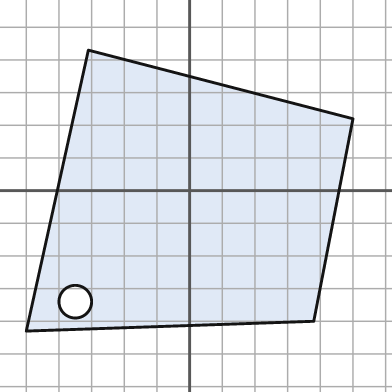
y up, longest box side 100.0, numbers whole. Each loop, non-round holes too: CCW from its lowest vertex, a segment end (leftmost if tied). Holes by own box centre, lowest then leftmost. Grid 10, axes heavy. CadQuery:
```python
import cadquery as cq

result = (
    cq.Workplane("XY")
    .moveTo(-50.0, -43.0)
    .lineTo(38.0, -40.0)
    .lineTo(50.0, 22.0)
    .lineTo(-31.0, 43.0)
    .close()
    .moveTo(-35.0, -34.0)
    .circle(5.0)
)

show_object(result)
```